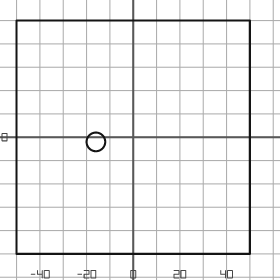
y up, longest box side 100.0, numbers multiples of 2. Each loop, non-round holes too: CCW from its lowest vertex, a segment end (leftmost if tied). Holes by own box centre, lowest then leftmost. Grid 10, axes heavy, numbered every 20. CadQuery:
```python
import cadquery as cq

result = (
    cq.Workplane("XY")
    .moveTo(-50.0, -50.0)
    .lineTo(50.0, -50.0)
    .lineTo(50.0, 50.0)
    .lineTo(-50.0, 50.0)
    .close()
    .moveTo(-16.0, -2.0)
    .circle(4.0)
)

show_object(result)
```